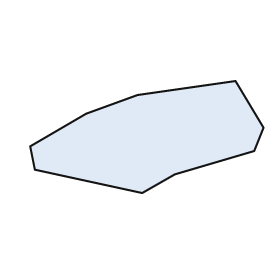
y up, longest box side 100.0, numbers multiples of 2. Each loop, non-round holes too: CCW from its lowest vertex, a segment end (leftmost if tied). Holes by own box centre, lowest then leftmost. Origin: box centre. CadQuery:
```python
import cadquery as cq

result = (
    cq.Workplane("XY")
    .moveTo(-2.0, -24.0)
    .lineTo(12.0, -16.0)
    .lineTo(46.0, -6.0)
    .lineTo(50.0, 4.0)
    .lineTo(38.0, 24.0)
    .lineTo(-4.0, 18.0)
    .lineTo(-26.0, 10.0)
    .lineTo(-50.0, -4.0)
    .lineTo(-48.0, -14.0)
    .close()
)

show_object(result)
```